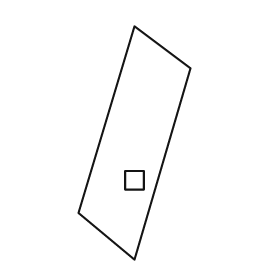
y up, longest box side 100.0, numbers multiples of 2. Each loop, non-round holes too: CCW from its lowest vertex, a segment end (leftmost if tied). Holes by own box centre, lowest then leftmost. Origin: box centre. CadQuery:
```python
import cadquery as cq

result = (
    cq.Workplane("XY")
    .moveTo(0.0, -50.0)
    .lineTo(24.0, 32.0)
    .lineTo(0.0, 50.0)
    .lineTo(-24.0, -30.0)
    .close()
    .moveTo(-4.0, -20.0)
    .lineTo(4.0, -20.0)
    .lineTo(4.0, -12.0)
    .lineTo(-4.0, -12.0)
    .close()
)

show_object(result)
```